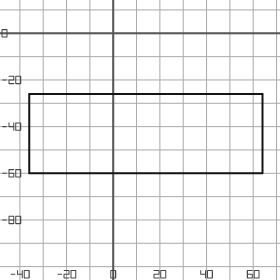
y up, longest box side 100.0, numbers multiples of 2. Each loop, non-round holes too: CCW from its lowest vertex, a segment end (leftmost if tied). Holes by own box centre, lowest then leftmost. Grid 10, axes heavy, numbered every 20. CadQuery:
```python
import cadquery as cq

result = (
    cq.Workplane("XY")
    .moveTo(-36.0, -60.0)
    .lineTo(64.0, -60.0)
    .lineTo(64.0, -26.0)
    .lineTo(-36.0, -26.0)
    .close()
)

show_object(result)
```